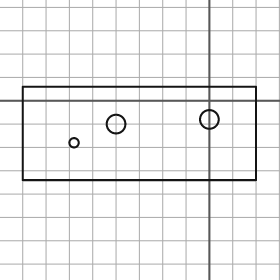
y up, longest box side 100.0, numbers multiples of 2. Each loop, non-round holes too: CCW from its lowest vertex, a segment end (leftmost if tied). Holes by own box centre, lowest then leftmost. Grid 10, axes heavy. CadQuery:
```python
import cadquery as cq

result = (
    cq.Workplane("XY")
    .moveTo(-80.0, -34.0)
    .lineTo(20.0, -34.0)
    .lineTo(20.0, 6.0)
    .lineTo(-80.0, 6.0)
    .close()
    .moveTo(-58.0, -18.0)
    .circle(2.0)
    .moveTo(-40.0, -10.0)
    .circle(4.0)
    .moveTo(0.0, -8.0)
    .circle(4.0)
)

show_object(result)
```